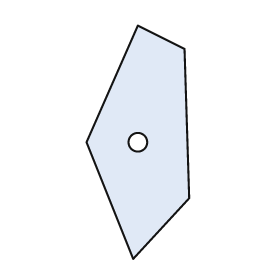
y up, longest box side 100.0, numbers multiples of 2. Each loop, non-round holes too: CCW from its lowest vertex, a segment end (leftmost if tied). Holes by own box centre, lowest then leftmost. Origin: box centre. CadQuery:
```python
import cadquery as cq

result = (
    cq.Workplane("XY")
    .moveTo(-2.0, -50.0)
    .lineTo(22.0, -24.0)
    .lineTo(20.0, 40.0)
    .lineTo(0.0, 50.0)
    .lineTo(-22.0, 0.0)
    .close()
    .moveTo(0.0, 0.0)
    .circle(4.0)
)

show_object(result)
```